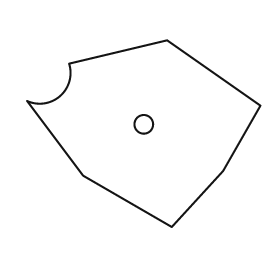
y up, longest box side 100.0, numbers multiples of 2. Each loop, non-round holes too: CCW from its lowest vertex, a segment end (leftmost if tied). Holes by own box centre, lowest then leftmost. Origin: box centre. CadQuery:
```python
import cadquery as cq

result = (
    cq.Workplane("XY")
    .moveTo(12.0, -40.0)
    .lineTo(34.0, -16.0)
    .lineTo(50.0, 12.0)
    .lineTo(10.0, 40.0)
    .lineTo(-32.0, 30.0)
    .threePointArc((-36.0, 16.0), (-50.0, 14.0))
    .lineTo(-26.0, -18.0)
    .close()
    .moveTo(0.0, 4.0)
    .circle(4.0)
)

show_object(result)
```